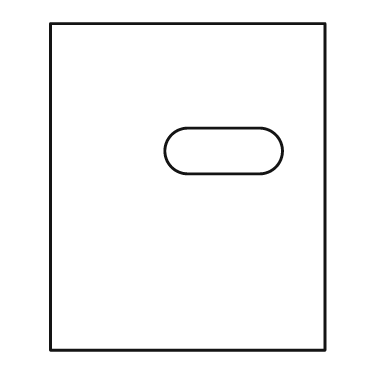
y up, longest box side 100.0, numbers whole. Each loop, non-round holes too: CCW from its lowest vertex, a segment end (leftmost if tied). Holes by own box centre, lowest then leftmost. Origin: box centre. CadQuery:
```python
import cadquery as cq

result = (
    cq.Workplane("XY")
    .moveTo(-42.0, -50.0)
    .lineTo(42.0, -50.0)
    .lineTo(42.0, 50.0)
    .lineTo(-42.0, 50.0)
    .close()
    .moveTo(0.0, 4.0)
    .lineTo(22.0, 4.0)
    .threePointArc((29.0, 11.0), (22.0, 18.0))
    .lineTo(0.0, 18.0)
    .threePointArc((-7.0, 11.0), (0.0, 4.0))
    .close()
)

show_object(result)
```